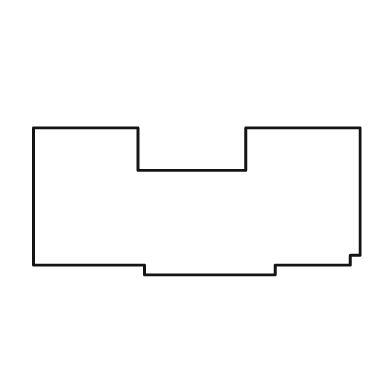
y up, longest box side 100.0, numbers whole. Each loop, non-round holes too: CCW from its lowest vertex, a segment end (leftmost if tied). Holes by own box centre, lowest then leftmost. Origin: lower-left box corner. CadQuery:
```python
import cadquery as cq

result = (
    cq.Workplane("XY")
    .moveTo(34.0, 0.0)
    .lineTo(74.0, 0.0)
    .lineTo(74.0, 3.0)
    .lineTo(97.0, 3.0)
    .lineTo(97.0, 6.0)
    .lineTo(100.0, 6.0)
    .lineTo(100.0, 45.0)
    .lineTo(65.0, 45.0)
    .lineTo(65.0, 32.0)
    .lineTo(32.0, 32.0)
    .lineTo(32.0, 45.0)
    .lineTo(0.0, 45.0)
    .lineTo(0.0, 3.0)
    .lineTo(34.0, 3.0)
    .close()
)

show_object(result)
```